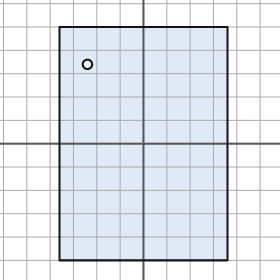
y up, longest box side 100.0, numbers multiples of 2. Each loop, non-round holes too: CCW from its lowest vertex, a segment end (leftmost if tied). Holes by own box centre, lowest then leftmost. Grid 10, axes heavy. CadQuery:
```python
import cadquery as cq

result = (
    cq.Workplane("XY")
    .moveTo(-36.0, -50.0)
    .lineTo(36.0, -50.0)
    .lineTo(36.0, 50.0)
    .lineTo(-36.0, 50.0)
    .close()
    .moveTo(-24.0, 34.0)
    .circle(2.0)
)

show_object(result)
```